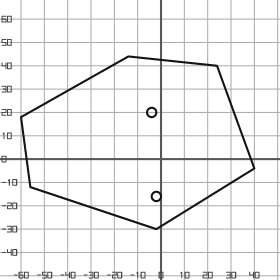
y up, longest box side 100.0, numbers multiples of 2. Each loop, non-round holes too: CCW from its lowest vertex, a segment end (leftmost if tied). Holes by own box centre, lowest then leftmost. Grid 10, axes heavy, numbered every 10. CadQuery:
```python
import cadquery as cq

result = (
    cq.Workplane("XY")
    .moveTo(-2.0, -30.0)
    .lineTo(40.0, -4.0)
    .lineTo(24.0, 40.0)
    .lineTo(-14.0, 44.0)
    .lineTo(-60.0, 18.0)
    .lineTo(-56.0, -12.0)
    .close()
    .moveTo(-2.0, -16.0)
    .circle(2.0)
    .moveTo(-4.0, 20.0)
    .circle(2.0)
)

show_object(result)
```